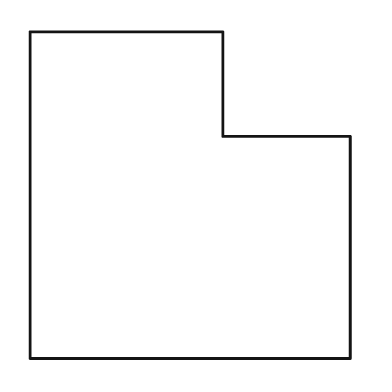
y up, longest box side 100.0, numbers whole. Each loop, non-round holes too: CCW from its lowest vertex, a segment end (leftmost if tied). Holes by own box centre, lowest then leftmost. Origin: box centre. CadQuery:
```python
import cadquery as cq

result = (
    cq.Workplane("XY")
    .moveTo(-49.0, -50.0)
    .lineTo(49.0, -50.0)
    .lineTo(49.0, 18.0)
    .lineTo(10.0, 18.0)
    .lineTo(10.0, 50.0)
    .lineTo(-49.0, 50.0)
    .close()
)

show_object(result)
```